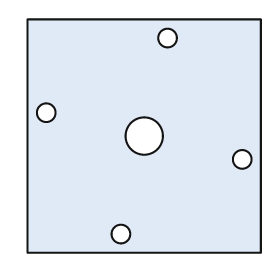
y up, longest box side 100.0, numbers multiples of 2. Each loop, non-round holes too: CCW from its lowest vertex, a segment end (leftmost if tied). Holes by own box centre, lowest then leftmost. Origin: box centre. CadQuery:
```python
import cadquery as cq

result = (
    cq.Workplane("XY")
    .moveTo(-50.0, -50.0)
    .lineTo(50.0, -50.0)
    .lineTo(50.0, 50.0)
    .lineTo(-50.0, 50.0)
    .close()
    .moveTo(-10.0, -42.0)
    .circle(4.0)
    .moveTo(42.0, -10.0)
    .circle(4.0)
    .moveTo(0.0, 0.0)
    .circle(8.0)
    .moveTo(-42.0, 10.0)
    .circle(4.0)
    .moveTo(10.0, 42.0)
    .circle(4.0)
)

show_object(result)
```